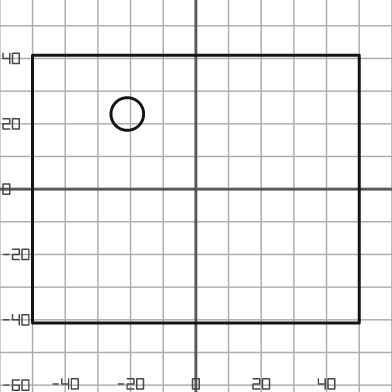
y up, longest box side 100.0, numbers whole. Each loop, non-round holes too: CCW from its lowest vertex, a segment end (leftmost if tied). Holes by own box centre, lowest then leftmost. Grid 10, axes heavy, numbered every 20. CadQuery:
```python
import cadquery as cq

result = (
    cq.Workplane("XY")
    .moveTo(-50.0, -41.0)
    .lineTo(50.0, -41.0)
    .lineTo(50.0, 41.0)
    .lineTo(-50.0, 41.0)
    .close()
    .moveTo(-21.0, 23.0)
    .circle(5.0)
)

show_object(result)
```